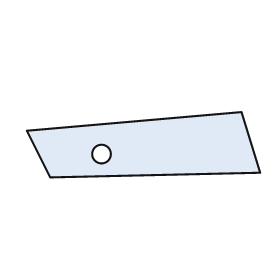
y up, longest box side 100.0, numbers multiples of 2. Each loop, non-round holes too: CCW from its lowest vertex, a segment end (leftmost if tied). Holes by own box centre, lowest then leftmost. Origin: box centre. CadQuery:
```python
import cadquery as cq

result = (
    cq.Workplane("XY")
    .moveTo(-40.0, -14.0)
    .lineTo(50.0, -12.0)
    .lineTo(42.0, 14.0)
    .lineTo(-50.0, 6.0)
    .close()
    .moveTo(-18.0, -4.0)
    .circle(4.0)
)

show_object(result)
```